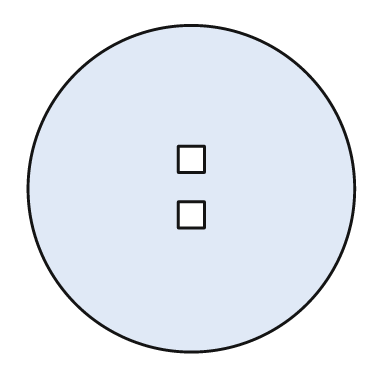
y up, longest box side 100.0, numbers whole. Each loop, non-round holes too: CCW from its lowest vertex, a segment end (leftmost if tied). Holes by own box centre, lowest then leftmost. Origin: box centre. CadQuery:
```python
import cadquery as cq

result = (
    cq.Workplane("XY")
    .moveTo(0.0, 0.0)
    .circle(50.0)
    .moveTo(-4.0, -12.0)
    .lineTo(4.0, -12.0)
    .lineTo(4.0, -4.0)
    .lineTo(-4.0, -4.0)
    .close()
    .moveTo(-4.0, 5.0)
    .lineTo(4.0, 5.0)
    .lineTo(4.0, 13.0)
    .lineTo(-4.0, 13.0)
    .close()
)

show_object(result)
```